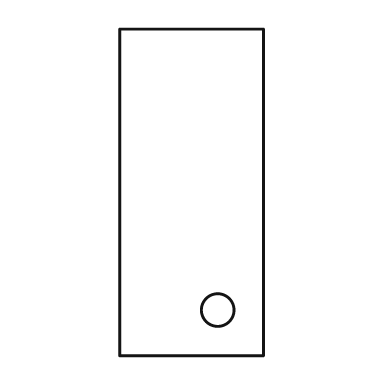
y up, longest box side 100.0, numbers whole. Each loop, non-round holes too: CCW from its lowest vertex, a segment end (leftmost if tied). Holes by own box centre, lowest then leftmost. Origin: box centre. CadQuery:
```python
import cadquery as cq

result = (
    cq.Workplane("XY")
    .moveTo(-22.0, -50.0)
    .lineTo(22.0, -50.0)
    .lineTo(22.0, 50.0)
    .lineTo(-22.0, 50.0)
    .close()
    .moveTo(8.0, -36.0)
    .circle(5.0)
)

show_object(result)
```